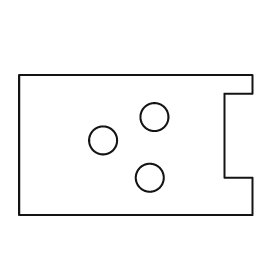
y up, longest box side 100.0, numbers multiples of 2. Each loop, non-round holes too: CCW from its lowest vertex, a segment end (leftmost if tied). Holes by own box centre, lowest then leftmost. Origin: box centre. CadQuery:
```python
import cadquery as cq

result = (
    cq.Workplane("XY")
    .moveTo(-50.0, -30.0)
    .lineTo(50.0, -30.0)
    .lineTo(50.0, -14.0)
    .lineTo(38.0, -14.0)
    .lineTo(38.0, 22.0)
    .lineTo(50.0, 22.0)
    .lineTo(50.0, 30.0)
    .lineTo(-50.0, 30.0)
    .close()
    .moveTo(6.0, -14.0)
    .circle(6.0)
    .moveTo(-14.0, 2.0)
    .circle(6.0)
    .moveTo(8.0, 12.0)
    .circle(6.0)
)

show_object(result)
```